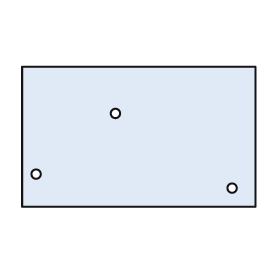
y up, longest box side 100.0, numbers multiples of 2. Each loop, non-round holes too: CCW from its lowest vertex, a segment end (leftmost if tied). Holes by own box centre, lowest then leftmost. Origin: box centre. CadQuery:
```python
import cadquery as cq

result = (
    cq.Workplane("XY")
    .moveTo(-50.0, -30.0)
    .lineTo(50.0, -30.0)
    .lineTo(50.0, 30.0)
    .lineTo(-50.0, 30.0)
    .close()
    .moveTo(40.0, -22.0)
    .circle(2.0)
    .moveTo(-44.0, -16.0)
    .circle(2.0)
    .moveTo(-10.0, 10.0)
    .circle(2.0)
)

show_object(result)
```